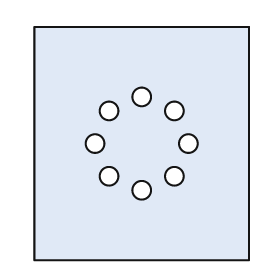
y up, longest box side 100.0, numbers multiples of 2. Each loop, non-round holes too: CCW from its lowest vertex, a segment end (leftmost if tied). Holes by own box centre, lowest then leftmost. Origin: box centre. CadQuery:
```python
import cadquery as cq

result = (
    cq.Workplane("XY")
    .moveTo(-46.0, -50.0)
    .lineTo(46.0, -50.0)
    .lineTo(46.0, 50.0)
    .lineTo(-46.0, 50.0)
    .close()
    .moveTo(0.0, -20.0)
    .circle(4.0)
    .moveTo(-14.0, -14.0)
    .circle(4.0)
    .moveTo(14.0, -14.0)
    .circle(4.0)
    .moveTo(-20.0, 0.0)
    .circle(4.0)
    .moveTo(20.0, 0.0)
    .circle(4.0)
    .moveTo(-14.0, 14.0)
    .circle(4.0)
    .moveTo(14.0, 14.0)
    .circle(4.0)
    .moveTo(0.0, 20.0)
    .circle(4.0)
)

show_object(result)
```